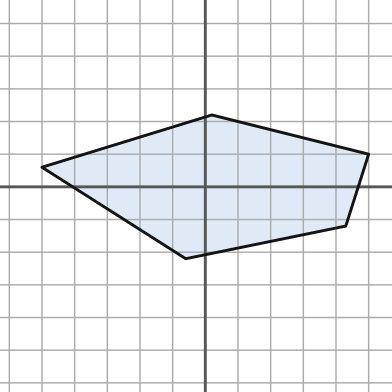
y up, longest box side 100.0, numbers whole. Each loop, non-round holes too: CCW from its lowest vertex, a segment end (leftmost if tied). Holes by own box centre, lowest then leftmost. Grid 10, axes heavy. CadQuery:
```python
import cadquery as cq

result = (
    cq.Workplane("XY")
    .moveTo(-6.0, -22.0)
    .lineTo(43.0, -12.0)
    .lineTo(50.0, 10.0)
    .lineTo(2.0, 22.0)
    .lineTo(-50.0, 6.0)
    .close()
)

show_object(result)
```